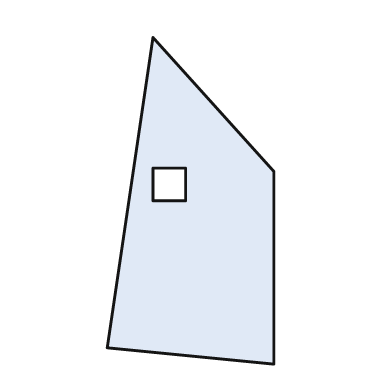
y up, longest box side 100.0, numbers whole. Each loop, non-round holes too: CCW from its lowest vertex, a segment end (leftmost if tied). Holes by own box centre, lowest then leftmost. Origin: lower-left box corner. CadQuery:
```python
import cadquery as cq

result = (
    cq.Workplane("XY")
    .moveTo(51.0, 0.0)
    .lineTo(51.0, 59.0)
    .lineTo(14.0, 100.0)
    .lineTo(0.0, 5.0)
    .close()
    .moveTo(14.0, 50.0)
    .lineTo(24.0, 50.0)
    .lineTo(24.0, 60.0)
    .lineTo(14.0, 60.0)
    .close()
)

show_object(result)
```